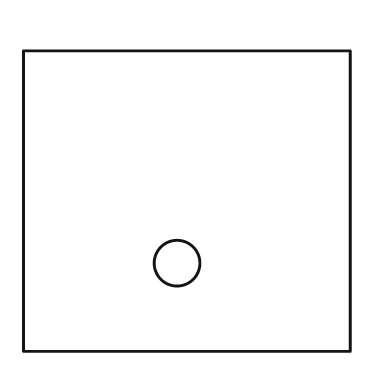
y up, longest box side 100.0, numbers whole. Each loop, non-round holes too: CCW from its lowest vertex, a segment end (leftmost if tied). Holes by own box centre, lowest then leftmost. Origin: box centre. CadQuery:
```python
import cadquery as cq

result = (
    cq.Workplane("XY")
    .moveTo(-50.0, -46.0)
    .lineTo(50.0, -46.0)
    .lineTo(50.0, 46.0)
    .lineTo(-50.0, 46.0)
    .close()
    .moveTo(-3.0, -19.0)
    .circle(7.0)
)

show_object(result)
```